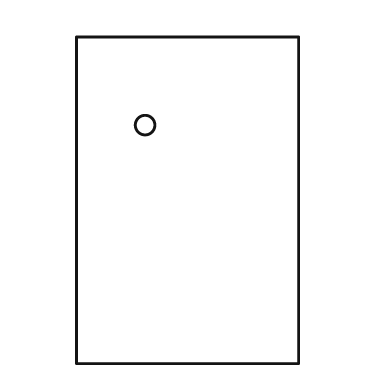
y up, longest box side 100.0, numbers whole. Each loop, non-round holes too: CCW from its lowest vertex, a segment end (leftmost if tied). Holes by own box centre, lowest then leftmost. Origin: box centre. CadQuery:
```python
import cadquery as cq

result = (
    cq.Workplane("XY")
    .moveTo(-34.0, -50.0)
    .lineTo(34.0, -50.0)
    .lineTo(34.0, 50.0)
    .lineTo(-34.0, 50.0)
    .close()
    .moveTo(-13.0, 23.0)
    .circle(3.0)
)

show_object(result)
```